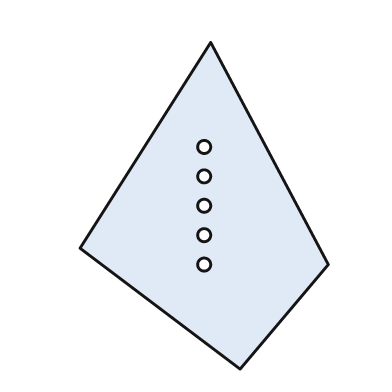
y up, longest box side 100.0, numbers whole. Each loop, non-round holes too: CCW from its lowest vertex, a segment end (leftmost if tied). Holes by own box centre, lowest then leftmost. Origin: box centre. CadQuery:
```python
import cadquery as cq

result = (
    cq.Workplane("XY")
    .moveTo(11.0, -50.0)
    .lineTo(38.0, -18.0)
    .lineTo(2.0, 50.0)
    .lineTo(-38.0, -13.0)
    .close()
    .moveTo(0.0, -18.0)
    .circle(2.0)
    .moveTo(0.0, -9.0)
    .circle(2.0)
    .moveTo(0.0, 0.0)
    .circle(2.0)
    .moveTo(0.0, 9.0)
    .circle(2.0)
    .moveTo(0.0, 18.0)
    .circle(2.0)
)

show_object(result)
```